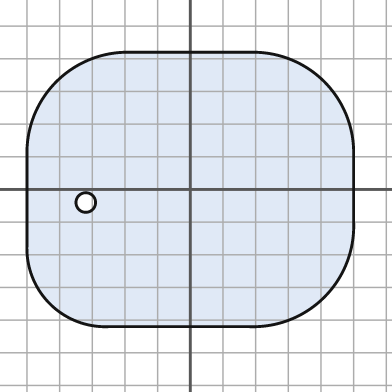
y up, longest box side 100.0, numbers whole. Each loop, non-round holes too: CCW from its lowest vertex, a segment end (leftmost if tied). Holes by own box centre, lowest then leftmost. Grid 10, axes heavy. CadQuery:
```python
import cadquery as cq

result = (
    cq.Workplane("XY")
    .moveTo(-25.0, -42.0)
    .lineTo(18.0, -42.0)
    .threePointArc((41.0, -33.0), (50.0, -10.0))
    .lineTo(50.0, 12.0)
    .threePointArc((41.0, 33.0), (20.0, 42.0))
    .lineTo(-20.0, 42.0)
    .threePointArc((-41.0, 33.0), (-50.0, 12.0))
    .lineTo(-50.0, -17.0)
    .threePointArc((-43.0, -35.0), (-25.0, -42.0))
    .close()
    .moveTo(-32.0, -4.0)
    .circle(3.0)
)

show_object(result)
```